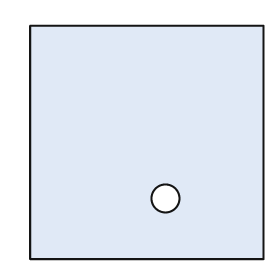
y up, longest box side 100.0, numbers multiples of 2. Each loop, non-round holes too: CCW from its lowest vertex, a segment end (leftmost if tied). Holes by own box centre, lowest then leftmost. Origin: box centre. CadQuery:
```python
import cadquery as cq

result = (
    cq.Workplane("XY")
    .moveTo(-50.0, -50.0)
    .lineTo(50.0, -50.0)
    .lineTo(50.0, 50.0)
    .lineTo(-50.0, 50.0)
    .close()
    .moveTo(8.0, -24.0)
    .circle(6.0)
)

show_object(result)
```